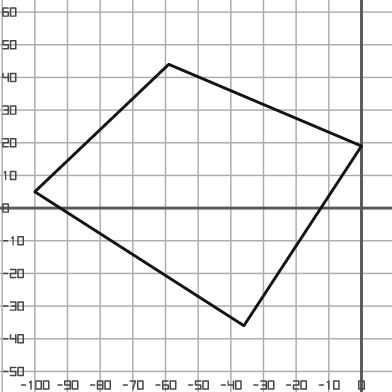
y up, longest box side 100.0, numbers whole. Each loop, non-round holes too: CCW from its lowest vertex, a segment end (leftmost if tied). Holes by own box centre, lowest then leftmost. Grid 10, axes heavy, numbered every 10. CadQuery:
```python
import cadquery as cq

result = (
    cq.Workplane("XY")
    .moveTo(-36.0, -36.0)
    .lineTo(0.0, 19.0)
    .lineTo(-59.0, 44.0)
    .lineTo(-100.0, 5.0)
    .close()
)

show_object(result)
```